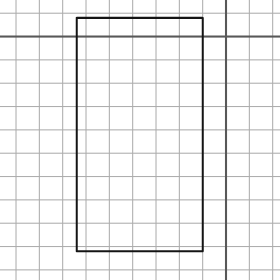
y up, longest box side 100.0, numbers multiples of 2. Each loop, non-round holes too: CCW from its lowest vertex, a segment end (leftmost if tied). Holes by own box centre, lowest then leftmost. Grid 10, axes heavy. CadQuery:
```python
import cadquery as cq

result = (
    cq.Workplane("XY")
    .moveTo(-64.0, -92.0)
    .lineTo(-10.0, -92.0)
    .lineTo(-10.0, 8.0)
    .lineTo(-64.0, 8.0)
    .close()
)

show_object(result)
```